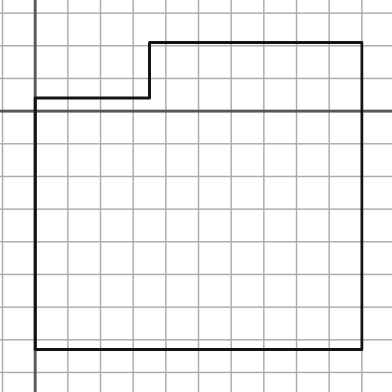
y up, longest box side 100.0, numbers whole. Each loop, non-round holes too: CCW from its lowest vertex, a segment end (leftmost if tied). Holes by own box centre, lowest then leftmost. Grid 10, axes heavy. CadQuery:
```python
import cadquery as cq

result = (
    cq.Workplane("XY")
    .moveTo(0.0, -73.0)
    .lineTo(100.0, -73.0)
    .lineTo(100.0, 21.0)
    .lineTo(35.0, 21.0)
    .lineTo(35.0, 4.0)
    .lineTo(0.0, 4.0)
    .close()
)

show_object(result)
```